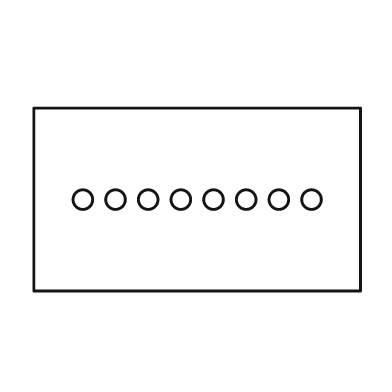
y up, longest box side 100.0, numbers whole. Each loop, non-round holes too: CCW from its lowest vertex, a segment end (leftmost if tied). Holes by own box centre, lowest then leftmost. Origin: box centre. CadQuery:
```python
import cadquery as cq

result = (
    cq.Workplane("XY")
    .moveTo(-50.0, -28.0)
    .lineTo(50.0, -28.0)
    .lineTo(50.0, 28.0)
    .lineTo(-50.0, 28.0)
    .close()
    .moveTo(-35.0, 0.0)
    .circle(3.0)
    .moveTo(-25.0, 0.0)
    .circle(3.0)
    .moveTo(-15.0, 0.0)
    .circle(3.0)
    .moveTo(-5.0, 0.0)
    .circle(3.0)
    .moveTo(5.0, 0.0)
    .circle(3.0)
    .moveTo(15.0, 0.0)
    .circle(3.0)
    .moveTo(25.0, 0.0)
    .circle(3.0)
    .moveTo(35.0, 0.0)
    .circle(3.0)
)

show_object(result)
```